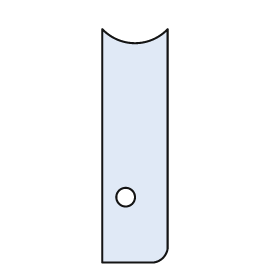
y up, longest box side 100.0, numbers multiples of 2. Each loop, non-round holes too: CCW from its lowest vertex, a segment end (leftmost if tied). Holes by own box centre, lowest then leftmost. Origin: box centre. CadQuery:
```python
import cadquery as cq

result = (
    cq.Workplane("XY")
    .moveTo(-14.0, -50.0)
    .lineTo(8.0, -50.0)
    .threePointArc((12.0, -48.0), (14.0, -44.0))
    .lineTo(14.0, 50.0)
    .threePointArc((0.0, 44.0), (-14.0, 50.0))
    .close()
    .moveTo(-4.0, -22.0)
    .circle(4.0)
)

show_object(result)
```